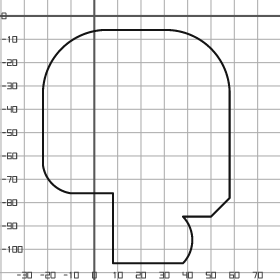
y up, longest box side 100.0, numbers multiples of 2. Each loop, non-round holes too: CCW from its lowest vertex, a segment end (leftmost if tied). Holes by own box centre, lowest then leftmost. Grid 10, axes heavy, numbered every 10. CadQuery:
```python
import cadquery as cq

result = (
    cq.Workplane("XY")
    .moveTo(8.0, -106.0)
    .lineTo(38.0, -106.0)
    .threePointArc((42.0, -96.0), (38.0, -86.0))
    .lineTo(50.0, -86.0)
    .lineTo(58.0, -78.0)
    .lineTo(58.0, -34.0)
    .threePointArc((50.0, -14.0), (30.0, -6.0))
    .lineTo(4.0, -6.0)
    .threePointArc((-14.0, -14.0), (-22.0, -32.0))
    .lineTo(-22.0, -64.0)
    .threePointArc((-18.0, -72.0), (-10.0, -76.0))
    .lineTo(8.0, -76.0)
    .close()
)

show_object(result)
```